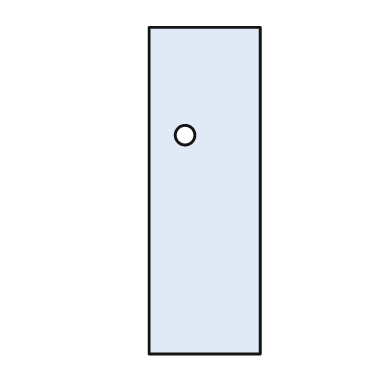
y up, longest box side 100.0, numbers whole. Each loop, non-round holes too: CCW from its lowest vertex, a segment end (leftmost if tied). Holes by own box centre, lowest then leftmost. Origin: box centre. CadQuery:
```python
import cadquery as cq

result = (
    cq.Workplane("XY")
    .moveTo(-17.0, -50.0)
    .lineTo(17.0, -50.0)
    .lineTo(17.0, 50.0)
    .lineTo(-17.0, 50.0)
    .close()
    .moveTo(-6.0, 17.0)
    .circle(3.0)
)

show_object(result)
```